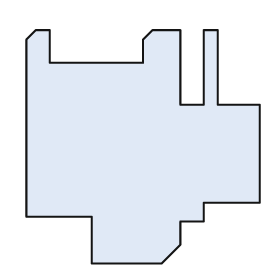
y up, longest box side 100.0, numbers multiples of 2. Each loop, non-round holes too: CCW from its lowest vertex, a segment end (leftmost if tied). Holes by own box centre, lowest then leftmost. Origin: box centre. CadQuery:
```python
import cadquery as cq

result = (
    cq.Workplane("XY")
    .moveTo(-22.0, -50.0)
    .lineTo(8.0, -50.0)
    .lineTo(16.0, -42.0)
    .lineTo(16.0, -32.0)
    .lineTo(26.0, -32.0)
    .lineTo(26.0, -24.0)
    .lineTo(50.0, -24.0)
    .lineTo(50.0, 18.0)
    .lineTo(32.0, 18.0)
    .lineTo(32.0, 50.0)
    .lineTo(26.0, 50.0)
    .lineTo(26.0, 18.0)
    .lineTo(16.0, 18.0)
    .lineTo(16.0, 50.0)
    .lineTo(4.0, 50.0)
    .lineTo(0.0, 46.0)
    .lineTo(0.0, 36.0)
    .lineTo(-40.0, 36.0)
    .lineTo(-40.0, 50.0)
    .lineTo(-46.0, 50.0)
    .lineTo(-50.0, 46.0)
    .lineTo(-50.0, -30.0)
    .lineTo(-22.0, -30.0)
    .close()
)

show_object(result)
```